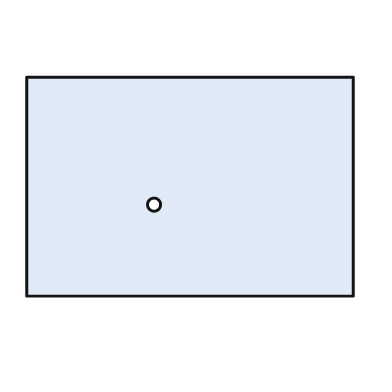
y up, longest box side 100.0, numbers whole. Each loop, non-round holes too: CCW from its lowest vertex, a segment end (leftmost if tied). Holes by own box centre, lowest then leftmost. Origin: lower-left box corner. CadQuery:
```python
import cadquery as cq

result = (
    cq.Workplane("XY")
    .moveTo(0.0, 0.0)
    .lineTo(100.0, 0.0)
    .lineTo(100.0, 67.0)
    .lineTo(0.0, 67.0)
    .close()
    .moveTo(39.0, 28.0)
    .circle(2.0)
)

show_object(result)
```